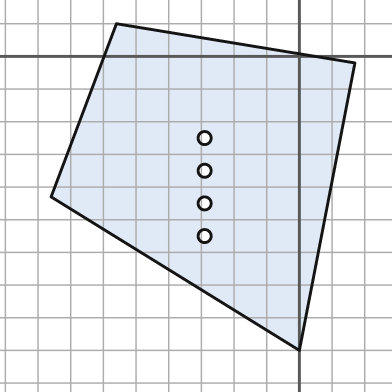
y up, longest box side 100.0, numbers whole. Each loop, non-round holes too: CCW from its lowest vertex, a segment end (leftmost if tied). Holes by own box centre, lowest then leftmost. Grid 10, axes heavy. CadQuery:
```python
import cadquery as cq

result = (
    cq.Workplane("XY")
    .moveTo(0.0, -90.0)
    .lineTo(17.0, -2.0)
    .lineTo(-56.0, 10.0)
    .lineTo(-76.0, -43.0)
    .close()
    .moveTo(-29.0, -55.0)
    .circle(2.0)
    .moveTo(-29.0, -45.0)
    .circle(2.0)
    .moveTo(-29.0, -35.0)
    .circle(2.0)
    .moveTo(-29.0, -25.0)
    .circle(2.0)
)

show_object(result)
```